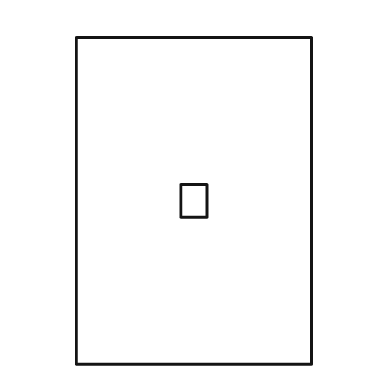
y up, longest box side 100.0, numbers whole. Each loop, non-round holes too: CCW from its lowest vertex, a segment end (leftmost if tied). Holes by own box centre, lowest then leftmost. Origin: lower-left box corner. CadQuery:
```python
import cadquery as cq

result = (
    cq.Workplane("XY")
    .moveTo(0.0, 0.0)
    .lineTo(72.0, 0.0)
    .lineTo(72.0, 100.0)
    .lineTo(0.0, 100.0)
    .close()
    .moveTo(32.0, 45.0)
    .lineTo(40.0, 45.0)
    .lineTo(40.0, 55.0)
    .lineTo(32.0, 55.0)
    .close()
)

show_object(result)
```